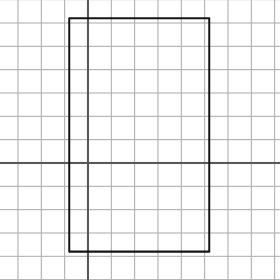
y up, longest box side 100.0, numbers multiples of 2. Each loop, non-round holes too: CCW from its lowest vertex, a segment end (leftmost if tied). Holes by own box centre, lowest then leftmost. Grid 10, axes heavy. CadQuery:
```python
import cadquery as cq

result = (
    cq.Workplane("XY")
    .moveTo(-8.0, -38.0)
    .lineTo(52.0, -38.0)
    .lineTo(52.0, 62.0)
    .lineTo(-8.0, 62.0)
    .close()
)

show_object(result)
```